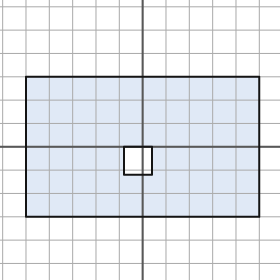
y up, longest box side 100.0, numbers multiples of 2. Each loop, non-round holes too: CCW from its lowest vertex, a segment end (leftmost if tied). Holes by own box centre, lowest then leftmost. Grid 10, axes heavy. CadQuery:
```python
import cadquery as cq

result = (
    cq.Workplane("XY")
    .moveTo(-50.0, -30.0)
    .lineTo(50.0, -30.0)
    .lineTo(50.0, 30.0)
    .lineTo(-50.0, 30.0)
    .close()
    .moveTo(-8.0, -12.0)
    .lineTo(4.0, -12.0)
    .lineTo(4.0, 0.0)
    .lineTo(-8.0, 0.0)
    .close()
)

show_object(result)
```